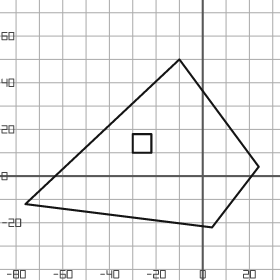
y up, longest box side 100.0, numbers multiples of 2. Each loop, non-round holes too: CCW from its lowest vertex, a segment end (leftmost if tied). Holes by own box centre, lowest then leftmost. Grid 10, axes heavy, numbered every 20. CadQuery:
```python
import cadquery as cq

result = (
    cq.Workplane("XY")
    .moveTo(4.0, -22.0)
    .lineTo(24.0, 4.0)
    .lineTo(-10.0, 50.0)
    .lineTo(-76.0, -12.0)
    .close()
    .moveTo(-30.0, 10.0)
    .lineTo(-22.0, 10.0)
    .lineTo(-22.0, 18.0)
    .lineTo(-30.0, 18.0)
    .close()
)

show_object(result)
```